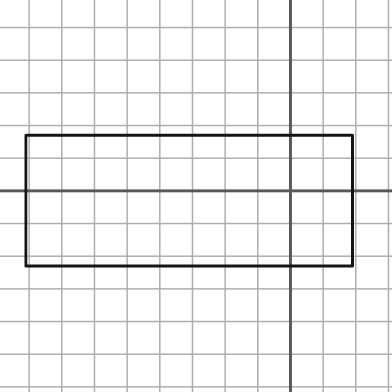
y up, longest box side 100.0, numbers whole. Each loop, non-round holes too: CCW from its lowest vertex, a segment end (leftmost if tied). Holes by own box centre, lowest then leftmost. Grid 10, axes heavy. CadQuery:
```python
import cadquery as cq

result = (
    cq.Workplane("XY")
    .moveTo(-81.0, -23.0)
    .lineTo(19.0, -23.0)
    .lineTo(19.0, 17.0)
    .lineTo(-81.0, 17.0)
    .close()
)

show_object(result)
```